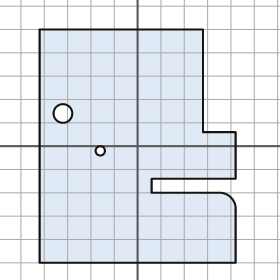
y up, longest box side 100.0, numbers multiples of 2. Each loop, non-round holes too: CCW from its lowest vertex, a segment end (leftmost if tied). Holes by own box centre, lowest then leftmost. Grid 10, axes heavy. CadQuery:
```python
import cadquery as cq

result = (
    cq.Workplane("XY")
    .moveTo(-42.0, -50.0)
    .lineTo(42.0, -50.0)
    .lineTo(42.0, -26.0)
    .threePointArc((40.0, -22.0), (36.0, -20.0))
    .lineTo(6.0, -20.0)
    .lineTo(6.0, -14.0)
    .lineTo(42.0, -14.0)
    .lineTo(42.0, 6.0)
    .lineTo(28.0, 6.0)
    .lineTo(28.0, 50.0)
    .lineTo(-42.0, 50.0)
    .close()
    .moveTo(-16.0, -2.0)
    .circle(2.0)
    .moveTo(-32.0, 14.0)
    .circle(4.0)
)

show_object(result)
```